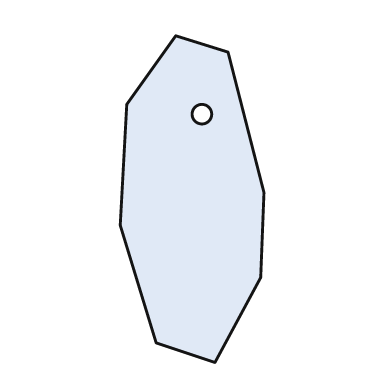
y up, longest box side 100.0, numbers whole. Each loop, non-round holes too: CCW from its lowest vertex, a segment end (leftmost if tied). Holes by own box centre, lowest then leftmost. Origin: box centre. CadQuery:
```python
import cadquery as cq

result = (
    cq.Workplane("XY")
    .moveTo(7.0, -50.0)
    .lineTo(21.0, -24.0)
    .lineTo(22.0, 2.0)
    .lineTo(11.0, 45.0)
    .lineTo(-5.0, 50.0)
    .lineTo(-20.0, 29.0)
    .lineTo(-22.0, -8.0)
    .lineTo(-11.0, -44.0)
    .close()
    .moveTo(3.0, 26.0)
    .circle(3.0)
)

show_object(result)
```